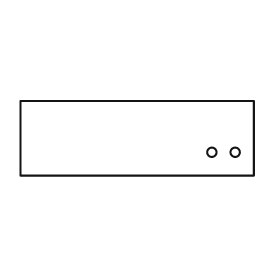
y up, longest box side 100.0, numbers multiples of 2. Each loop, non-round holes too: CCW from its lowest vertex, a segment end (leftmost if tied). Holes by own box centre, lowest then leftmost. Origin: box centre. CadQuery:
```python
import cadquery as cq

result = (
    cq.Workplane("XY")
    .moveTo(-50.0, -16.0)
    .lineTo(50.0, -16.0)
    .lineTo(50.0, 16.0)
    .lineTo(-50.0, 16.0)
    .close()
    .moveTo(32.0, -6.0)
    .circle(2.0)
    .moveTo(42.0, -6.0)
    .circle(2.0)
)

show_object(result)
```